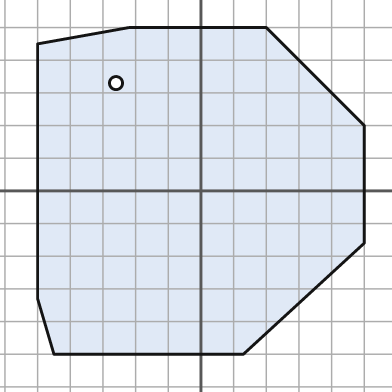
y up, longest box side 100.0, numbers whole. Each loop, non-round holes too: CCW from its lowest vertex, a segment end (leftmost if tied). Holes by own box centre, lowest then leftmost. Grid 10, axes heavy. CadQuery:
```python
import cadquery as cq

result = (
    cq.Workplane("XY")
    .moveTo(-45.0, -50.0)
    .lineTo(13.0, -50.0)
    .lineTo(50.0, -16.0)
    .lineTo(50.0, 20.0)
    .lineTo(20.0, 50.0)
    .lineTo(-22.0, 50.0)
    .lineTo(-50.0, 45.0)
    .lineTo(-50.0, -33.0)
    .close()
    .moveTo(-26.0, 33.0)
    .circle(2.0)
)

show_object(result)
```